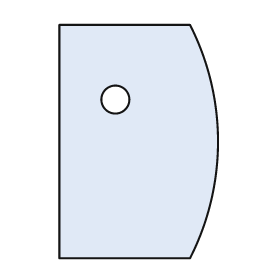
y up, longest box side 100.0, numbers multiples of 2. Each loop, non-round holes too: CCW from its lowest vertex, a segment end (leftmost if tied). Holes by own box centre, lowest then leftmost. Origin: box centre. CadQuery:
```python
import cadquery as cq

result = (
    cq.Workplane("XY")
    .moveTo(-34.0, -50.0)
    .lineTo(22.0, -50.0)
    .threePointArc((34.0, 0.0), (22.0, 50.0))
    .lineTo(-34.0, 50.0)
    .close()
    .moveTo(-10.0, 18.0)
    .circle(6.0)
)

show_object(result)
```